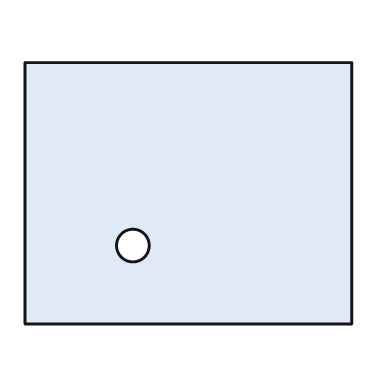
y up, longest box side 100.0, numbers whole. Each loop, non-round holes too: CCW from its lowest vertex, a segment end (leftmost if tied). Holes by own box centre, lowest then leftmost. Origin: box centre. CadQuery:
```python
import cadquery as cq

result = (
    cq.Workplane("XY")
    .moveTo(-50.0, -40.0)
    .lineTo(50.0, -40.0)
    .lineTo(50.0, 40.0)
    .lineTo(-50.0, 40.0)
    .close()
    .moveTo(-17.0, -16.0)
    .circle(5.0)
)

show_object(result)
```